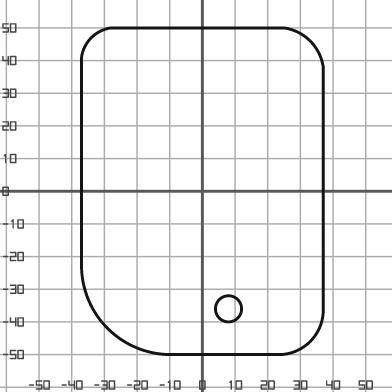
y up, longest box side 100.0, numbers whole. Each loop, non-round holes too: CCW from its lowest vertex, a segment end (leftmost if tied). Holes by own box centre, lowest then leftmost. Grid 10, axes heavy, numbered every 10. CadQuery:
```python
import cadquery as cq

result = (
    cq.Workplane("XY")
    .moveTo(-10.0, -50.0)
    .lineTo(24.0, -50.0)
    .threePointArc((33.0, -46.0), (37.0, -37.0))
    .lineTo(37.0, 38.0)
    .threePointArc((33.0, 46.0), (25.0, 50.0))
    .lineTo(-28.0, 50.0)
    .threePointArc((-34.0, 47.0), (-37.0, 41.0))
    .lineTo(-37.0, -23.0)
    .threePointArc((-29.0, -42.0), (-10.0, -50.0))
    .close()
    .moveTo(8.0, -36.0)
    .circle(4.0)
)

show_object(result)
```